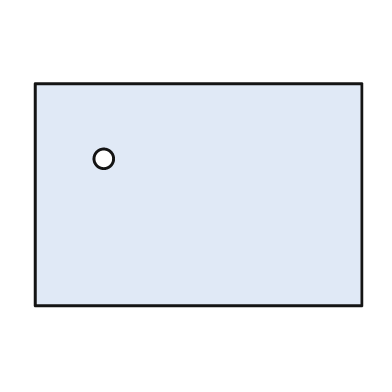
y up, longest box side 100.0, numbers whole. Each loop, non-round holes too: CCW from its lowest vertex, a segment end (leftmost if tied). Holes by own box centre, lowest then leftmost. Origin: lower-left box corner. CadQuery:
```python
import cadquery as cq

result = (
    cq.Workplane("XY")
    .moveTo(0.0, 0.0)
    .lineTo(100.0, 0.0)
    .lineTo(100.0, 68.0)
    .lineTo(0.0, 68.0)
    .close()
    .moveTo(21.0, 45.0)
    .circle(3.0)
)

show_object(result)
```